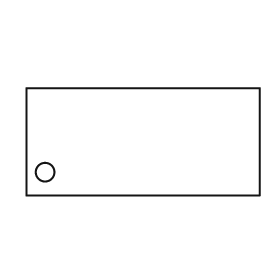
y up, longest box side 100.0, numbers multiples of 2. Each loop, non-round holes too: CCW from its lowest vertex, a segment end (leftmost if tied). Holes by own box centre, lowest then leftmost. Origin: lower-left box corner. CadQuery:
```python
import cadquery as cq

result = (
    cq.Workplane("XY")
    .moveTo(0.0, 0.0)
    .lineTo(100.0, 0.0)
    .lineTo(100.0, 46.0)
    .lineTo(0.0, 46.0)
    .close()
    .moveTo(8.0, 10.0)
    .circle(4.0)
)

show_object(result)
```